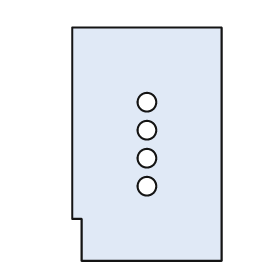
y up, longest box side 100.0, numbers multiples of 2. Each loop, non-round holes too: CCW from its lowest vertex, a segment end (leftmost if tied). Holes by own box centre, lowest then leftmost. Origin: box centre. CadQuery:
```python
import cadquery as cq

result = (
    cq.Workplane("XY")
    .moveTo(-28.0, -50.0)
    .lineTo(32.0, -50.0)
    .lineTo(32.0, 50.0)
    .lineTo(-32.0, 50.0)
    .lineTo(-32.0, -32.0)
    .lineTo(-28.0, -32.0)
    .close()
    .moveTo(0.0, -18.0)
    .circle(4.0)
    .moveTo(0.0, -6.0)
    .circle(4.0)
    .moveTo(0.0, 6.0)
    .circle(4.0)
    .moveTo(0.0, 18.0)
    .circle(4.0)
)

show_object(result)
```